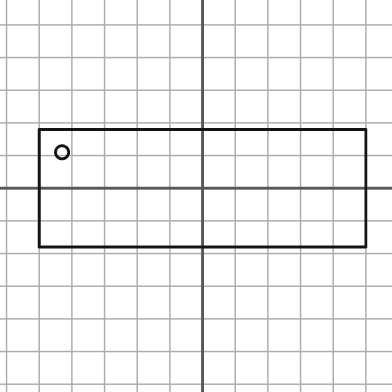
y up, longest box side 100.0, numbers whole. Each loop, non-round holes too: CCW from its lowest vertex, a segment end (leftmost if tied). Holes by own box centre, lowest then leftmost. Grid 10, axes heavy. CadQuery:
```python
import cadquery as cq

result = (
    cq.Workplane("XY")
    .moveTo(-50.0, -18.0)
    .lineTo(50.0, -18.0)
    .lineTo(50.0, 18.0)
    .lineTo(-50.0, 18.0)
    .close()
    .moveTo(-43.0, 11.0)
    .circle(2.0)
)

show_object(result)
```